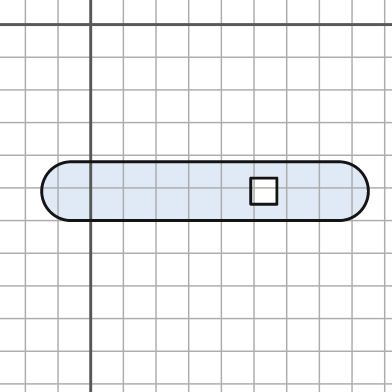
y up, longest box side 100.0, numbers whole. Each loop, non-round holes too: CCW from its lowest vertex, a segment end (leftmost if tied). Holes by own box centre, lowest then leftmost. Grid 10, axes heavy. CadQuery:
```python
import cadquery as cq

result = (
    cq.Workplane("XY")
    .moveTo(-6.0, -60.0)
    .lineTo(76.0, -60.0)
    .threePointArc((85.0, -51.0), (76.0, -42.0))
    .lineTo(-6.0, -42.0)
    .threePointArc((-15.0, -51.0), (-6.0, -60.0))
    .close()
    .moveTo(49.0, -55.0)
    .lineTo(57.0, -55.0)
    .lineTo(57.0, -47.0)
    .lineTo(49.0, -47.0)
    .close()
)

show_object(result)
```